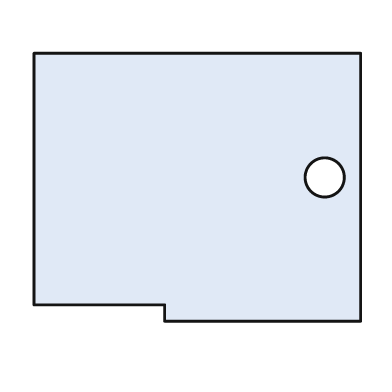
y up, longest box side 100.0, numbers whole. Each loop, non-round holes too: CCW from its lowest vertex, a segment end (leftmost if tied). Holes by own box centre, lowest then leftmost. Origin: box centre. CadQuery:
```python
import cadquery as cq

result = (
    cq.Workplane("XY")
    .moveTo(-10.0, -41.0)
    .lineTo(50.0, -41.0)
    .lineTo(50.0, 41.0)
    .lineTo(-50.0, 41.0)
    .lineTo(-50.0, -36.0)
    .lineTo(-10.0, -36.0)
    .close()
    .moveTo(39.0, 3.0)
    .circle(6.0)
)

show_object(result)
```